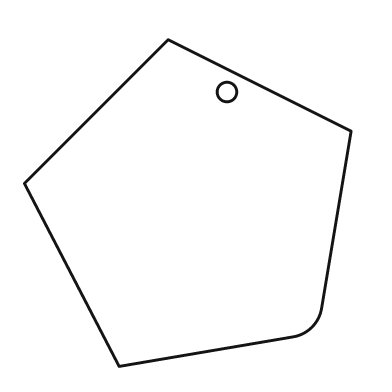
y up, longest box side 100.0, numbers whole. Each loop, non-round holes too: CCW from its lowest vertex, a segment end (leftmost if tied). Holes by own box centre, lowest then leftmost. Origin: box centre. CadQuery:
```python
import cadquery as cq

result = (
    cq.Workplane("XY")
    .moveTo(-21.0, -50.0)
    .lineTo(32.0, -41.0)
    .threePointArc((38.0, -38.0), (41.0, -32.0))
    .lineTo(50.0, 22.0)
    .lineTo(-6.0, 50.0)
    .lineTo(-50.0, 6.0)
    .close()
    .moveTo(12.0, 34.0)
    .circle(3.0)
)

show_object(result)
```